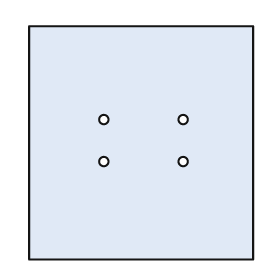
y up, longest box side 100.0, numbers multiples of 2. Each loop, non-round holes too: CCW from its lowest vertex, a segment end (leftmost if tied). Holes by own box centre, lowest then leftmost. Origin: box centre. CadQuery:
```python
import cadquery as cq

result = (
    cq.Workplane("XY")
    .moveTo(-48.0, -50.0)
    .lineTo(48.0, -50.0)
    .lineTo(48.0, 50.0)
    .lineTo(-48.0, 50.0)
    .close()
    .moveTo(-16.0, -8.0)
    .circle(2.0)
    .moveTo(18.0, -8.0)
    .circle(2.0)
    .moveTo(-16.0, 10.0)
    .circle(2.0)
    .moveTo(18.0, 10.0)
    .circle(2.0)
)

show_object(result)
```